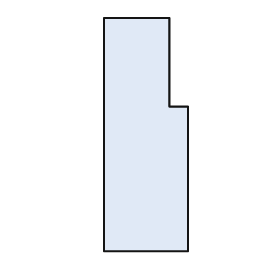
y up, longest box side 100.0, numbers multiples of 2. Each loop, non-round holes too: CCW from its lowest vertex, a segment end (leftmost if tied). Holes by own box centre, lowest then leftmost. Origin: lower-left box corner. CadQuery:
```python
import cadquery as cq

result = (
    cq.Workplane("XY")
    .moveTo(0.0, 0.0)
    .lineTo(36.0, 0.0)
    .lineTo(36.0, 62.0)
    .lineTo(28.0, 62.0)
    .lineTo(28.0, 100.0)
    .lineTo(0.0, 100.0)
    .close()
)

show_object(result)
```